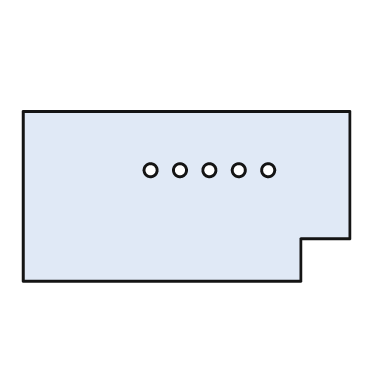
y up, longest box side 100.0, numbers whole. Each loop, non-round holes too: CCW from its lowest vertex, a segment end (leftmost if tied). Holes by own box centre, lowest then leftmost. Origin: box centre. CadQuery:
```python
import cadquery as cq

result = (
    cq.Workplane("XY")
    .moveTo(-50.0, -26.0)
    .lineTo(35.0, -26.0)
    .lineTo(35.0, -13.0)
    .lineTo(50.0, -13.0)
    .lineTo(50.0, 26.0)
    .lineTo(-50.0, 26.0)
    .close()
    .moveTo(-11.0, 8.0)
    .circle(2.0)
    .moveTo(-2.0, 8.0)
    .circle(2.0)
    .moveTo(7.0, 8.0)
    .circle(2.0)
    .moveTo(16.0, 8.0)
    .circle(2.0)
    .moveTo(25.0, 8.0)
    .circle(2.0)
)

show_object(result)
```